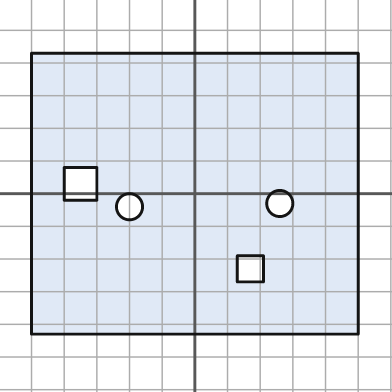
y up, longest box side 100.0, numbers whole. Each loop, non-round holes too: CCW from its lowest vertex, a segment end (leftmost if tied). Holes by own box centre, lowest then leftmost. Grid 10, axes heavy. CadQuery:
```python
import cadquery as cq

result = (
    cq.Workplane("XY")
    .moveTo(-50.0, -43.0)
    .lineTo(50.0, -43.0)
    .lineTo(50.0, 43.0)
    .lineTo(-50.0, 43.0)
    .close()
    .moveTo(13.0, -27.0)
    .lineTo(21.0, -27.0)
    .lineTo(21.0, -19.0)
    .lineTo(13.0, -19.0)
    .close()
    .moveTo(-20.0, -4.0)
    .circle(4.0)
    .moveTo(26.0, -3.0)
    .circle(4.0)
    .moveTo(-40.0, -2.0)
    .lineTo(-30.0, -2.0)
    .lineTo(-30.0, 8.0)
    .lineTo(-40.0, 8.0)
    .close()
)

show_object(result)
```